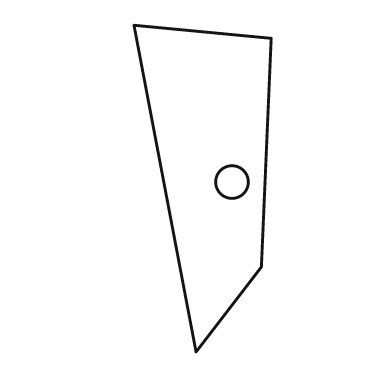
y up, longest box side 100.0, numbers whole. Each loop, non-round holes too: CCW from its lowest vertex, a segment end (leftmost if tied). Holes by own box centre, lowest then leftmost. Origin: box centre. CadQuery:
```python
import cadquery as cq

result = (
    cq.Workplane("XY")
    .moveTo(-2.0, -50.0)
    .lineTo(18.0, -24.0)
    .lineTo(21.0, 46.0)
    .lineTo(-21.0, 50.0)
    .close()
    .moveTo(9.0, 2.0)
    .circle(5.0)
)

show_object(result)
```